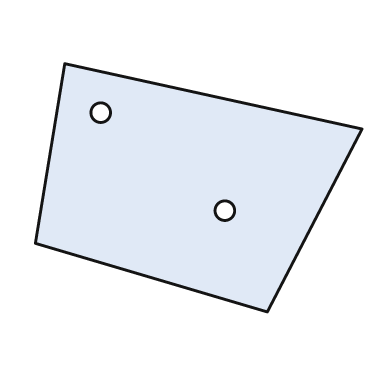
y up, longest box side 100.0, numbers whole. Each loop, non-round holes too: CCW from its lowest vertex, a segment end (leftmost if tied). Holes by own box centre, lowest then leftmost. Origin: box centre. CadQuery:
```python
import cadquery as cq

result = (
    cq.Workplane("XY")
    .moveTo(21.0, -38.0)
    .lineTo(50.0, 18.0)
    .lineTo(-41.0, 38.0)
    .lineTo(-50.0, -17.0)
    .close()
    .moveTo(8.0, -7.0)
    .circle(3.0)
    .moveTo(-30.0, 23.0)
    .circle(3.0)
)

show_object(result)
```